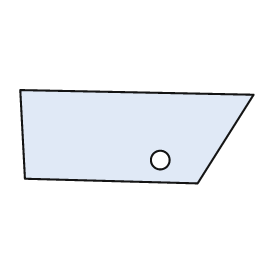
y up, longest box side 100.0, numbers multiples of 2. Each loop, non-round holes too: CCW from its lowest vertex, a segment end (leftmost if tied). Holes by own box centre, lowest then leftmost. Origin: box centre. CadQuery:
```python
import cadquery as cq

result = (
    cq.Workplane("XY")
    .moveTo(26.0, -20.0)
    .lineTo(50.0, 18.0)
    .lineTo(-50.0, 20.0)
    .lineTo(-48.0, -18.0)
    .close()
    .moveTo(10.0, -10.0)
    .circle(4.0)
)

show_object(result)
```